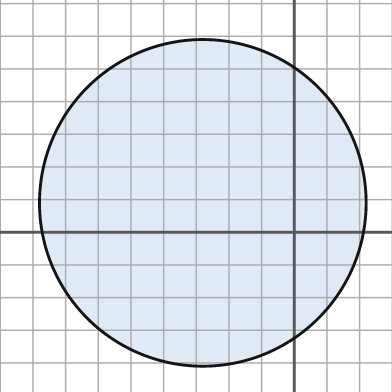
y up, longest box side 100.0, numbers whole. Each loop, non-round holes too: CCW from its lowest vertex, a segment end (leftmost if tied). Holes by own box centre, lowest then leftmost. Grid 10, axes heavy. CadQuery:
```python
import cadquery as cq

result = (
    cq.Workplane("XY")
    .moveTo(-28.0, 9.0)
    .circle(50.0)
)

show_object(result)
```